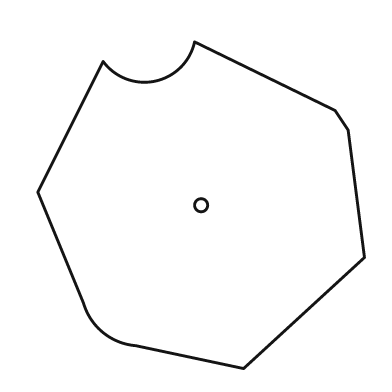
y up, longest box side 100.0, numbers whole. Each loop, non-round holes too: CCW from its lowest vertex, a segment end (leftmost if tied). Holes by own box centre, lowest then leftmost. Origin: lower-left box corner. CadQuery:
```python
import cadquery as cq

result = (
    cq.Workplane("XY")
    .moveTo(63.0, 0.0)
    .lineTo(100.0, 34.0)
    .lineTo(95.0, 73.0)
    .lineTo(91.0, 79.0)
    .lineTo(48.0, 100.0)
    .threePointArc((36.0, 88.0), (20.0, 94.0))
    .lineTo(0.0, 54.0)
    .lineTo(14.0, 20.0)
    .threePointArc((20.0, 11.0), (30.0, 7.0))
    .close()
    .moveTo(50.0, 50.0)
    .circle(2.0)
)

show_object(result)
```